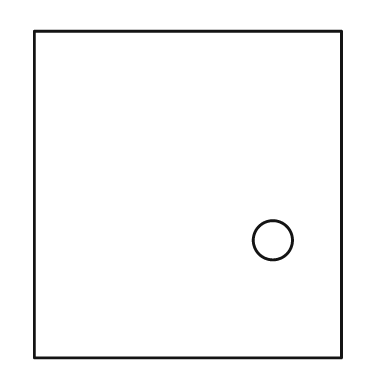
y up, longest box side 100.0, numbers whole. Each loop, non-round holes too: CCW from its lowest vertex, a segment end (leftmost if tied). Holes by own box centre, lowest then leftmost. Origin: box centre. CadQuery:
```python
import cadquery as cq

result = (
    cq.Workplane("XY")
    .moveTo(-47.0, -50.0)
    .lineTo(47.0, -50.0)
    .lineTo(47.0, 50.0)
    .lineTo(-47.0, 50.0)
    .close()
    .moveTo(26.0, -14.0)
    .circle(6.0)
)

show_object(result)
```